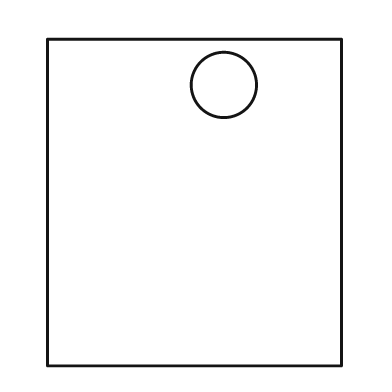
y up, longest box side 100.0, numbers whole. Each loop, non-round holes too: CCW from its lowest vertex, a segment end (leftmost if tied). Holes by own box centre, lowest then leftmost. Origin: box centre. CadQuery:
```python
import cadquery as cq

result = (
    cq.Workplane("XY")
    .moveTo(-45.0, -50.0)
    .lineTo(45.0, -50.0)
    .lineTo(45.0, 50.0)
    .lineTo(-45.0, 50.0)
    .close()
    .moveTo(9.0, 36.0)
    .circle(10.0)
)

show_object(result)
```